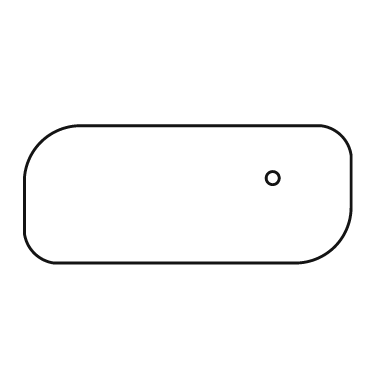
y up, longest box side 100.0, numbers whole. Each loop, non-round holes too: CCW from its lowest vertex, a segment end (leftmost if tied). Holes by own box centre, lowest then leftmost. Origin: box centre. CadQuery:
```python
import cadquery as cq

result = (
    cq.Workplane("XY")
    .moveTo(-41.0, -21.0)
    .lineTo(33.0, -21.0)
    .threePointArc((45.0, -16.0), (50.0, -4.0))
    .lineTo(50.0, 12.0)
    .threePointArc((47.0, 18.0), (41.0, 21.0))
    .lineTo(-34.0, 21.0)
    .threePointArc((-45.0, 16.0), (-50.0, 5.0))
    .lineTo(-50.0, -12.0)
    .threePointArc((-47.0, -18.0), (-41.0, -21.0))
    .close()
    .moveTo(26.0, 5.0)
    .circle(2.0)
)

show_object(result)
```